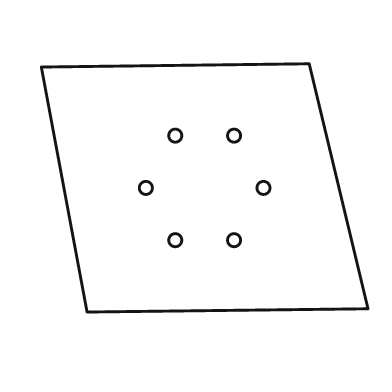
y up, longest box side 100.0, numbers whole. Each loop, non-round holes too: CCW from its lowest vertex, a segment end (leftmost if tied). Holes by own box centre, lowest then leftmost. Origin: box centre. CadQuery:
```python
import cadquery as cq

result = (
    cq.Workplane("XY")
    .moveTo(-36.0, -38.0)
    .lineTo(50.0, -37.0)
    .lineTo(32.0, 38.0)
    .lineTo(-50.0, 37.0)
    .close()
    .moveTo(-9.0, -16.0)
    .circle(2.0)
    .moveTo(9.0, -16.0)
    .circle(2.0)
    .moveTo(-18.0, 0.0)
    .circle(2.0)
    .moveTo(18.0, 0.0)
    .circle(2.0)
    .moveTo(-9.0, 16.0)
    .circle(2.0)
    .moveTo(9.0, 16.0)
    .circle(2.0)
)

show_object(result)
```